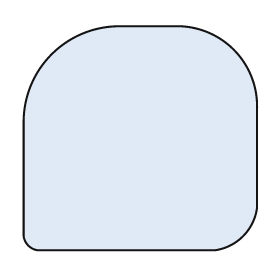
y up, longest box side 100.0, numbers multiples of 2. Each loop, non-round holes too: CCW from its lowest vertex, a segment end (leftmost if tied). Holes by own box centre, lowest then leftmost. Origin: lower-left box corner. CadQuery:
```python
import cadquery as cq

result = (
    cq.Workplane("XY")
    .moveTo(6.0, 0.0)
    .lineTo(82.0, 0.0)
    .threePointArc((94.0, 6.0), (100.0, 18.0))
    .lineTo(100.0, 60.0)
    .threePointArc((90.0, 86.0), (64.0, 96.0))
    .lineTo(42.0, 96.0)
    .threePointArc((12.0, 84.0), (0.0, 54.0))
    .lineTo(0.0, 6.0)
    .threePointArc((2.0, 2.0), (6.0, 0.0))
    .close()
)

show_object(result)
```